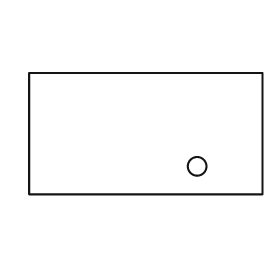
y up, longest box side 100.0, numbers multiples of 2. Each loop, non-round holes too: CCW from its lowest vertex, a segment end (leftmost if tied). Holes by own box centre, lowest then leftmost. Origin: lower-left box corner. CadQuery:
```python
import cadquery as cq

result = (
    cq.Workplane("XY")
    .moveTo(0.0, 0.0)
    .lineTo(100.0, 0.0)
    .lineTo(100.0, 52.0)
    .lineTo(0.0, 52.0)
    .close()
    .moveTo(72.0, 12.0)
    .circle(4.0)
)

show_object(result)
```